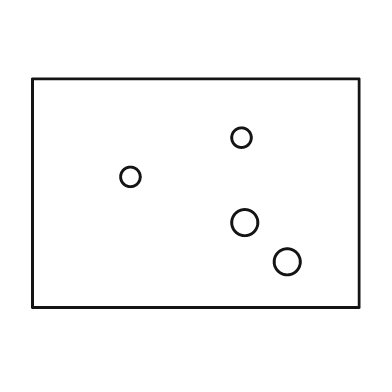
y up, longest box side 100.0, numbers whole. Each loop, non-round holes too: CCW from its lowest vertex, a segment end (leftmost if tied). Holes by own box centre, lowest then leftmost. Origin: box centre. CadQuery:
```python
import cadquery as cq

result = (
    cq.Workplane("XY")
    .moveTo(-50.0, -35.0)
    .lineTo(50.0, -35.0)
    .lineTo(50.0, 35.0)
    .lineTo(-50.0, 35.0)
    .close()
    .moveTo(28.0, -21.0)
    .circle(4.0)
    .moveTo(15.0, -9.0)
    .circle(4.0)
    .moveTo(-20.0, 5.0)
    .circle(3.0)
    .moveTo(14.0, 17.0)
    .circle(3.0)
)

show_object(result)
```